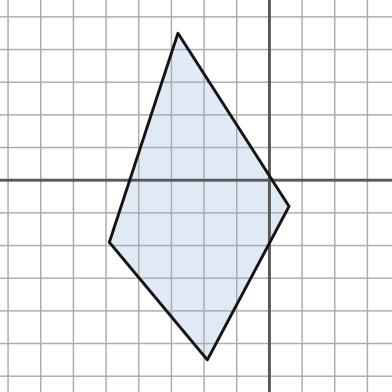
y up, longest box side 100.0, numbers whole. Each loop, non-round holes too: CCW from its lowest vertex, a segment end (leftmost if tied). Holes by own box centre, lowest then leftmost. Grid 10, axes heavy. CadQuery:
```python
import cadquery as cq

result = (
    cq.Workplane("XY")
    .moveTo(-19.0, -55.0)
    .lineTo(6.0, -8.0)
    .lineTo(-28.0, 45.0)
    .lineTo(-49.0, -19.0)
    .close()
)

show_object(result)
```